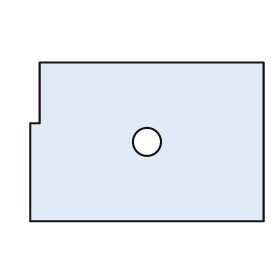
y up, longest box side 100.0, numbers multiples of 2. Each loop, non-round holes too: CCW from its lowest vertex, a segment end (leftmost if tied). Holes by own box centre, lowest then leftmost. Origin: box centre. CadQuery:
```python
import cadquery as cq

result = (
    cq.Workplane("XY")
    .moveTo(-50.0, -34.0)
    .lineTo(50.0, -34.0)
    .lineTo(50.0, 34.0)
    .lineTo(-46.0, 34.0)
    .lineTo(-46.0, 8.0)
    .lineTo(-50.0, 8.0)
    .close()
    .moveTo(0.0, 0.0)
    .circle(6.0)
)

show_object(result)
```